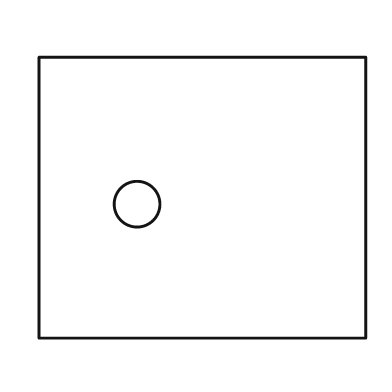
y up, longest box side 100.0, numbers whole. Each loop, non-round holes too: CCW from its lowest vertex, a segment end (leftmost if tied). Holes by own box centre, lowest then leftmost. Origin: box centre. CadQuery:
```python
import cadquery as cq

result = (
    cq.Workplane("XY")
    .moveTo(-50.0, -43.0)
    .lineTo(50.0, -43.0)
    .lineTo(50.0, 43.0)
    .lineTo(-50.0, 43.0)
    .close()
    .moveTo(-20.0, -2.0)
    .circle(7.0)
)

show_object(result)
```